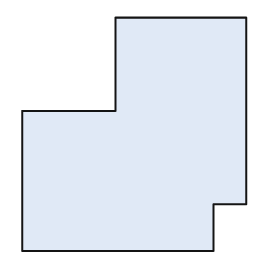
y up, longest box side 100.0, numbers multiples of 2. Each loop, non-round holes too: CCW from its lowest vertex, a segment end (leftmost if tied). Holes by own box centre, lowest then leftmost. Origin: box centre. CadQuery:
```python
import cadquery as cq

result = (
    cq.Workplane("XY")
    .moveTo(-48.0, -50.0)
    .lineTo(34.0, -50.0)
    .lineTo(34.0, -30.0)
    .lineTo(48.0, -30.0)
    .lineTo(48.0, 50.0)
    .lineTo(-8.0, 50.0)
    .lineTo(-8.0, 10.0)
    .lineTo(-48.0, 10.0)
    .close()
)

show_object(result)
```